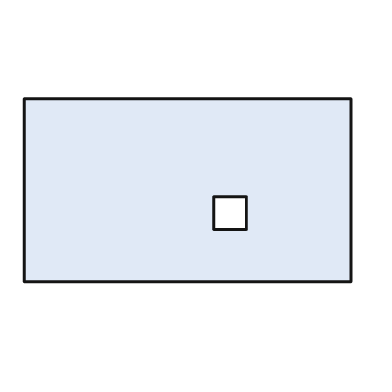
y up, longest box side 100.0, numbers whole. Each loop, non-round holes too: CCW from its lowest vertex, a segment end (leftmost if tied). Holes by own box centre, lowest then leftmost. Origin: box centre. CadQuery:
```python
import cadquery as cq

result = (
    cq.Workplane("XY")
    .moveTo(-50.0, -28.0)
    .lineTo(50.0, -28.0)
    .lineTo(50.0, 28.0)
    .lineTo(-50.0, 28.0)
    .close()
    .moveTo(8.0, -12.0)
    .lineTo(18.0, -12.0)
    .lineTo(18.0, -2.0)
    .lineTo(8.0, -2.0)
    .close()
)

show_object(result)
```